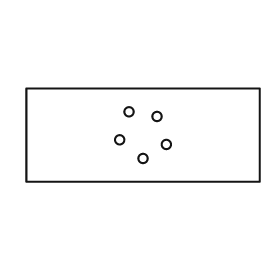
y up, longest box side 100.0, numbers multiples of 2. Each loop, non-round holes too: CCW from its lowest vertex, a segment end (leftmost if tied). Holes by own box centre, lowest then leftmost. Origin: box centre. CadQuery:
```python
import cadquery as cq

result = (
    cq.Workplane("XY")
    .moveTo(-50.0, -20.0)
    .lineTo(50.0, -20.0)
    .lineTo(50.0, 20.0)
    .lineTo(-50.0, 20.0)
    .close()
    .moveTo(0.0, -10.0)
    .circle(2.0)
    .moveTo(10.0, -4.0)
    .circle(2.0)
    .moveTo(-10.0, -2.0)
    .circle(2.0)
    .moveTo(6.0, 8.0)
    .circle(2.0)
    .moveTo(-6.0, 10.0)
    .circle(2.0)
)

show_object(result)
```